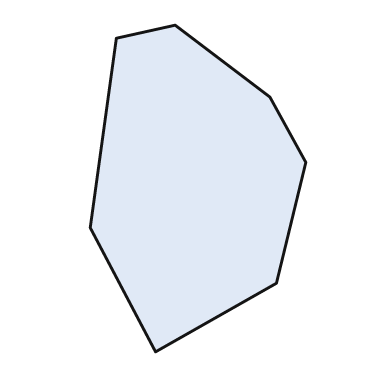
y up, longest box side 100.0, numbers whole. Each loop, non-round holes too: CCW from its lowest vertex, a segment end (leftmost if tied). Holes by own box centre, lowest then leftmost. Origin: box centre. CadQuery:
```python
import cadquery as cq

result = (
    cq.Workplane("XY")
    .moveTo(-13.0, -50.0)
    .lineTo(24.0, -29.0)
    .lineTo(33.0, 8.0)
    .lineTo(22.0, 28.0)
    .lineTo(-7.0, 50.0)
    .lineTo(-25.0, 46.0)
    .lineTo(-33.0, -12.0)
    .close()
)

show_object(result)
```